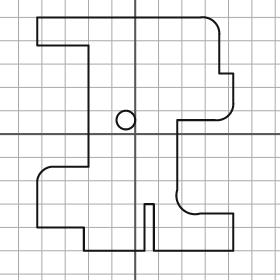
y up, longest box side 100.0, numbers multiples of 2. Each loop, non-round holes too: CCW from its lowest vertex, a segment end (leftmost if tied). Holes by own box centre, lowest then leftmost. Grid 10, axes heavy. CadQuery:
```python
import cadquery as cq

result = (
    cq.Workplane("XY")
    .moveTo(-22.0, -50.0)
    .lineTo(4.0, -50.0)
    .lineTo(4.0, -30.0)
    .lineTo(8.0, -30.0)
    .lineTo(8.0, -50.0)
    .lineTo(42.0, -50.0)
    .lineTo(42.0, -34.0)
    .lineTo(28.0, -34.0)
    .threePointArc((20.0, -32.0), (18.0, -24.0))
    .lineTo(18.0, 6.0)
    .lineTo(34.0, 6.0)
    .threePointArc((40.0, 8.0), (42.0, 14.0))
    .lineTo(42.0, 26.0)
    .lineTo(36.0, 26.0)
    .lineTo(36.0, 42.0)
    .threePointArc((34.0, 48.0), (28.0, 50.0))
    .lineTo(-42.0, 50.0)
    .lineTo(-42.0, 38.0)
    .lineTo(-20.0, 38.0)
    .lineTo(-20.0, -14.0)
    .lineTo(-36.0, -14.0)
    .threePointArc((-40.0, -16.0), (-42.0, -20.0))
    .lineTo(-42.0, -40.0)
    .lineTo(-22.0, -40.0)
    .close()
    .moveTo(-4.0, 6.0)
    .circle(4.0)
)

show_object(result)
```